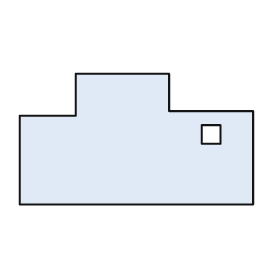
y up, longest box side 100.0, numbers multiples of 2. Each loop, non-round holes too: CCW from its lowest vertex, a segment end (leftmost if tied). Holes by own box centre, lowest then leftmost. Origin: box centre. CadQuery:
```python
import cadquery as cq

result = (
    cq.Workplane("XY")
    .moveTo(-50.0, -28.0)
    .lineTo(50.0, -28.0)
    .lineTo(50.0, 12.0)
    .lineTo(14.0, 12.0)
    .lineTo(14.0, 28.0)
    .lineTo(-26.0, 28.0)
    .lineTo(-26.0, 10.0)
    .lineTo(-50.0, 10.0)
    .close()
    .moveTo(28.0, -2.0)
    .lineTo(36.0, -2.0)
    .lineTo(36.0, 6.0)
    .lineTo(28.0, 6.0)
    .close()
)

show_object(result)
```